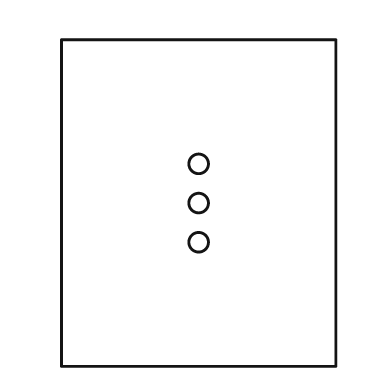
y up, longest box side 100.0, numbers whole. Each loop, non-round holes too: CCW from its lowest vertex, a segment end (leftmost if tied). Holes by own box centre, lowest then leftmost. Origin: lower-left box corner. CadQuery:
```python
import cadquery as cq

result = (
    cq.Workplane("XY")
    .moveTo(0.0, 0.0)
    .lineTo(84.0, 0.0)
    .lineTo(84.0, 100.0)
    .lineTo(0.0, 100.0)
    .close()
    .moveTo(42.0, 38.0)
    .circle(3.0)
    .moveTo(42.0, 50.0)
    .circle(3.0)
    .moveTo(42.0, 62.0)
    .circle(3.0)
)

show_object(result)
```